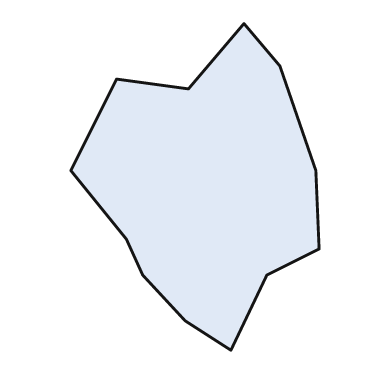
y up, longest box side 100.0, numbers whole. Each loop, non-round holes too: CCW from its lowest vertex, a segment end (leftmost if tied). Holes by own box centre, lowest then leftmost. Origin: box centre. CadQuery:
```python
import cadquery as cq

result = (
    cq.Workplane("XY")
    .moveTo(11.0, -50.0)
    .lineTo(22.0, -27.0)
    .lineTo(38.0, -19.0)
    .lineTo(37.0, 5.0)
    .lineTo(26.0, 37.0)
    .lineTo(15.0, 50.0)
    .lineTo(-2.0, 30.0)
    .lineTo(-24.0, 33.0)
    .lineTo(-38.0, 5.0)
    .lineTo(-21.0, -16.0)
    .lineTo(-16.0, -27.0)
    .lineTo(-3.0, -41.0)
    .close()
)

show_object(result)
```